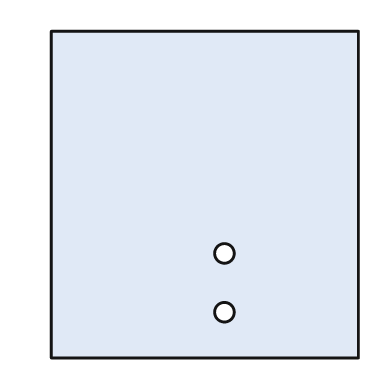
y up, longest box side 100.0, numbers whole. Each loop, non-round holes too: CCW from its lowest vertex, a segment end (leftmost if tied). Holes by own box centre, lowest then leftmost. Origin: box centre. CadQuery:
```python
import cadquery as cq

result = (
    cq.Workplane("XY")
    .moveTo(-47.0, -50.0)
    .lineTo(47.0, -50.0)
    .lineTo(47.0, 50.0)
    .lineTo(-47.0, 50.0)
    .close()
    .moveTo(6.0, -36.0)
    .circle(3.0)
    .moveTo(6.0, -18.0)
    .circle(3.0)
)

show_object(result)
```